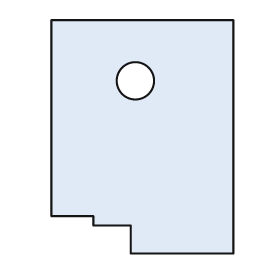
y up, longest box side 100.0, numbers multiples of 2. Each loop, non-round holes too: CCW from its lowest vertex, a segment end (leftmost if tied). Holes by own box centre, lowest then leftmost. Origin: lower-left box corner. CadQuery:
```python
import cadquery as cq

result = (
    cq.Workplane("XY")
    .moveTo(34.0, 0.0)
    .lineTo(78.0, 0.0)
    .lineTo(78.0, 100.0)
    .lineTo(0.0, 100.0)
    .lineTo(0.0, 16.0)
    .lineTo(18.0, 16.0)
    .lineTo(18.0, 12.0)
    .lineTo(34.0, 12.0)
    .close()
    .moveTo(36.0, 74.0)
    .circle(8.0)
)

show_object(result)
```